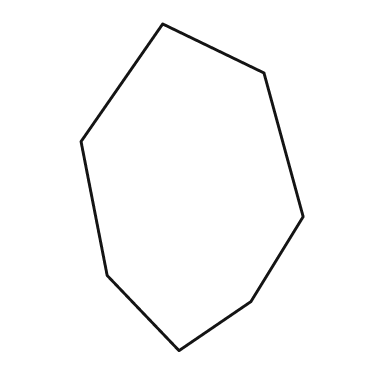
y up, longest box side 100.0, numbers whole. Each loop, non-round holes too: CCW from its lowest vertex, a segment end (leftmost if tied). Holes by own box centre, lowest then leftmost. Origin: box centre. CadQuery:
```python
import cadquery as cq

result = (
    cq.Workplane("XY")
    .moveTo(-4.0, -50.0)
    .lineTo(18.0, -35.0)
    .lineTo(34.0, -9.0)
    .lineTo(22.0, 35.0)
    .lineTo(-9.0, 50.0)
    .lineTo(-34.0, 14.0)
    .lineTo(-26.0, -27.0)
    .close()
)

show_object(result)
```